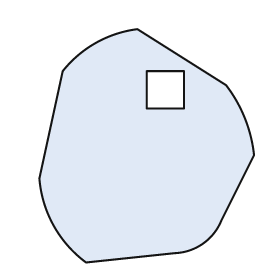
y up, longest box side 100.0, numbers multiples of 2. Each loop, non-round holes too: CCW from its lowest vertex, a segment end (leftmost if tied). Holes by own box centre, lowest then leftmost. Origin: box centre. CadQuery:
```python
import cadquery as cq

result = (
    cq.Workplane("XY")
    .moveTo(-26.0, -50.0)
    .lineTo(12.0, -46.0)
    .threePointArc((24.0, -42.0), (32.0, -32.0))
    .lineTo(46.0, -4.0)
    .threePointArc((42.0, 12.0), (34.0, 26.0))
    .lineTo(-4.0, 50.0)
    .threePointArc((-22.0, 44.0), (-36.0, 32.0))
    .lineTo(-46.0, -14.0)
    .threePointArc((-40.0, -34.0), (-26.0, -50.0))
    .close()
    .moveTo(0.0, 16.0)
    .lineTo(16.0, 16.0)
    .lineTo(16.0, 32.0)
    .lineTo(0.0, 32.0)
    .close()
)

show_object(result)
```